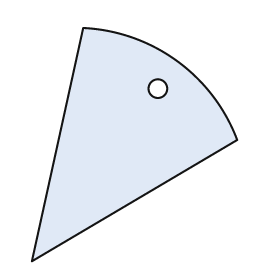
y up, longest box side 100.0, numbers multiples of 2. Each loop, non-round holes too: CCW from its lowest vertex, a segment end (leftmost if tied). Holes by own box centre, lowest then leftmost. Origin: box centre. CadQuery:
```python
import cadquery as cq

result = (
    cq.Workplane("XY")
    .moveTo(-44.0, -50.0)
    .lineTo(44.0, 2.0)
    .threePointArc((18.0, 36.0), (-22.0, 50.0))
    .close()
    .moveTo(10.0, 24.0)
    .circle(4.0)
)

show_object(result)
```